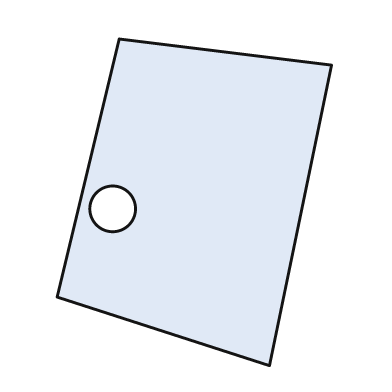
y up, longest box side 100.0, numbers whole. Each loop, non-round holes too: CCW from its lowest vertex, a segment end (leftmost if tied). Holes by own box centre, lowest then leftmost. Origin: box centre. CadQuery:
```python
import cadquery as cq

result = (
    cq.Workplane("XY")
    .moveTo(23.0, -50.0)
    .lineTo(42.0, 42.0)
    .lineTo(-23.0, 50.0)
    .lineTo(-42.0, -29.0)
    .close()
    .moveTo(-25.0, -2.0)
    .circle(7.0)
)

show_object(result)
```